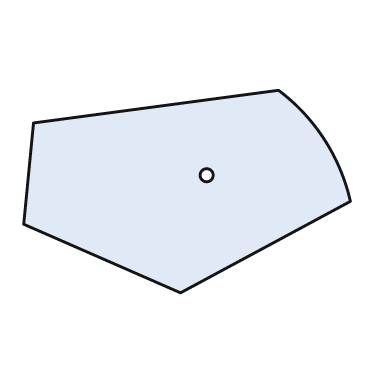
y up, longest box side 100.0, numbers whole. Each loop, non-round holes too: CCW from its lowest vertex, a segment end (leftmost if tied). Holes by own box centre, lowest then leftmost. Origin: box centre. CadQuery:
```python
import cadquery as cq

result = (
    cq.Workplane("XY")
    .moveTo(-2.0, -31.0)
    .lineTo(50.0, -3.0)
    .threePointArc((42.0, 16.0), (28.0, 31.0))
    .lineTo(-47.0, 21.0)
    .lineTo(-50.0, -10.0)
    .close()
    .moveTo(6.0, 5.0)
    .circle(2.0)
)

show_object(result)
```